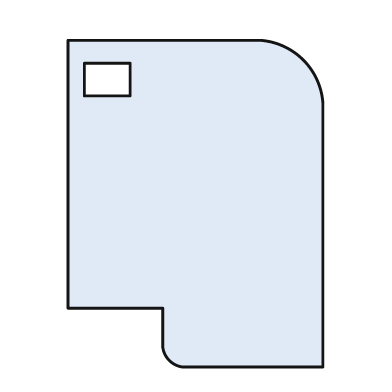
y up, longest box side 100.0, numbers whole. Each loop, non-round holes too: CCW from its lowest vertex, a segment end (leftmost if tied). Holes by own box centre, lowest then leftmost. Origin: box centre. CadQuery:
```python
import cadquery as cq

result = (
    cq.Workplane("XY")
    .moveTo(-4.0, -50.0)
    .lineTo(39.0, -50.0)
    .lineTo(39.0, 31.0)
    .threePointArc((33.0, 44.0), (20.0, 50.0))
    .lineTo(-39.0, 50.0)
    .lineTo(-39.0, -32.0)
    .lineTo(-10.0, -32.0)
    .lineTo(-10.0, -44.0)
    .threePointArc((-8.0, -48.0), (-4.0, -50.0))
    .close()
    .moveTo(-34.0, 33.0)
    .lineTo(-20.0, 33.0)
    .lineTo(-20.0, 43.0)
    .lineTo(-34.0, 43.0)
    .close()
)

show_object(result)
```